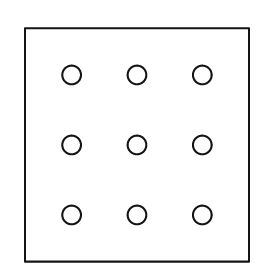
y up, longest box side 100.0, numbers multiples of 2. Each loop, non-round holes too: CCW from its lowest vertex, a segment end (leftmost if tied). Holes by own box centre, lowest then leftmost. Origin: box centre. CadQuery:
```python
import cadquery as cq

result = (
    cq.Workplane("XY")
    .moveTo(-48.0, -50.0)
    .lineTo(48.0, -50.0)
    .lineTo(48.0, 50.0)
    .lineTo(-48.0, 50.0)
    .close()
    .moveTo(-28.0, -30.0)
    .circle(4.0)
    .moveTo(0.0, -30.0)
    .circle(4.0)
    .moveTo(28.0, -30.0)
    .circle(4.0)
    .moveTo(-28.0, 0.0)
    .circle(4.0)
    .moveTo(0.0, 0.0)
    .circle(4.0)
    .moveTo(28.0, 0.0)
    .circle(4.0)
    .moveTo(-28.0, 30.0)
    .circle(4.0)
    .moveTo(0.0, 30.0)
    .circle(4.0)
    .moveTo(28.0, 30.0)
    .circle(4.0)
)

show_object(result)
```